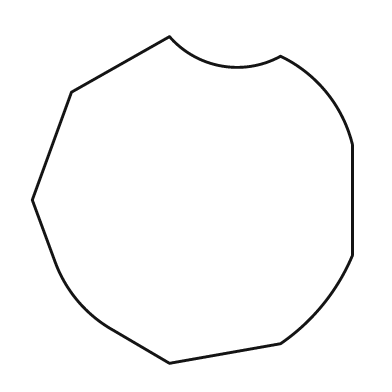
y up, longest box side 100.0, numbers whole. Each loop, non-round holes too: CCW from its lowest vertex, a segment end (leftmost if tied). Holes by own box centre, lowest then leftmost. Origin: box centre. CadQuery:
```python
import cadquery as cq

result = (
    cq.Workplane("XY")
    .moveTo(-7.0, -50.0)
    .lineTo(27.0, -44.0)
    .threePointArc((40.0, -32.0), (49.0, -17.0))
    .lineTo(49.0, 17.0)
    .threePointArc((41.0, 33.0), (27.0, 44.0))
    .threePointArc((9.0, 41.0), (-7.0, 50.0))
    .lineTo(-37.0, 33.0)
    .lineTo(-49.0, 0.0)
    .lineTo(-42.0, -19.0)
    .threePointArc((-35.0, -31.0), (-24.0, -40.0))
    .close()
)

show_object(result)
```